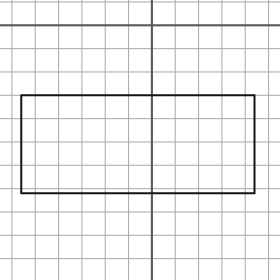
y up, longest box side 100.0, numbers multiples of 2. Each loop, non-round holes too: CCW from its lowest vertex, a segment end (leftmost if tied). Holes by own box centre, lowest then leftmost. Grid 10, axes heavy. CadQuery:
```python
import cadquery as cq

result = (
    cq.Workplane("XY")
    .moveTo(-56.0, -72.0)
    .lineTo(44.0, -72.0)
    .lineTo(44.0, -30.0)
    .lineTo(-56.0, -30.0)
    .close()
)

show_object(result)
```